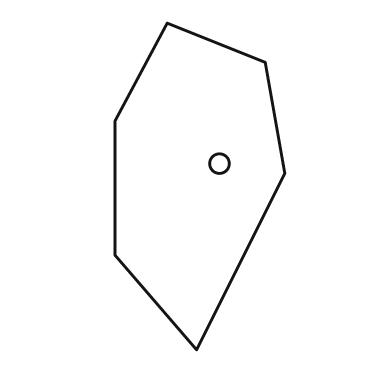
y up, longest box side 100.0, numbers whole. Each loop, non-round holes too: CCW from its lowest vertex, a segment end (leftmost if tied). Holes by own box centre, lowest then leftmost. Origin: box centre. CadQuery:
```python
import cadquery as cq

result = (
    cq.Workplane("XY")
    .moveTo(-1.0, -50.0)
    .lineTo(26.0, 4.0)
    .lineTo(20.0, 38.0)
    .lineTo(-10.0, 50.0)
    .lineTo(-26.0, 20.0)
    .lineTo(-26.0, -21.0)
    .close()
    .moveTo(6.0, 7.0)
    .circle(3.0)
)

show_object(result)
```